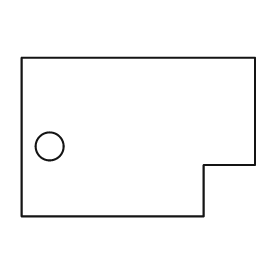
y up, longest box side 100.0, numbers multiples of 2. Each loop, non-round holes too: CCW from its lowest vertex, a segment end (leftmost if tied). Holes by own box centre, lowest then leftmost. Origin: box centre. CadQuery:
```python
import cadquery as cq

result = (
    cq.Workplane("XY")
    .moveTo(-50.0, -34.0)
    .lineTo(28.0, -34.0)
    .lineTo(28.0, -12.0)
    .lineTo(50.0, -12.0)
    .lineTo(50.0, 34.0)
    .lineTo(-50.0, 34.0)
    .close()
    .moveTo(-38.0, -4.0)
    .circle(6.0)
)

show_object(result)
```